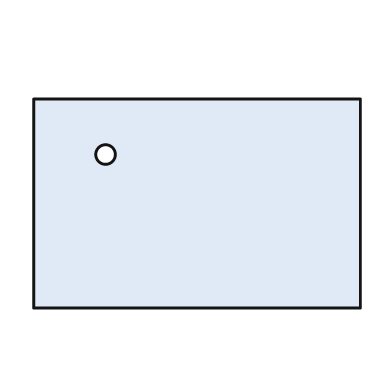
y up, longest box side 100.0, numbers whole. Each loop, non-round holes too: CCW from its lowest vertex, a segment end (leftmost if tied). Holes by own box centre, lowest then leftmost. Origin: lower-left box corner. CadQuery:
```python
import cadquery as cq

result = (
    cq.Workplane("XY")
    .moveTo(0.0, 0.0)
    .lineTo(100.0, 0.0)
    .lineTo(100.0, 64.0)
    .lineTo(0.0, 64.0)
    .close()
    .moveTo(22.0, 47.0)
    .circle(3.0)
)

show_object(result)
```